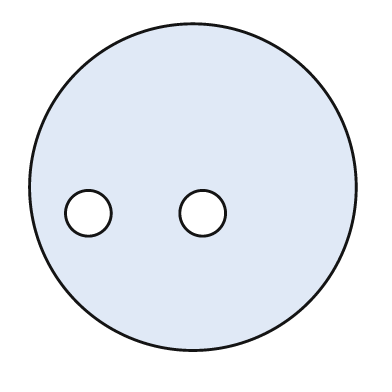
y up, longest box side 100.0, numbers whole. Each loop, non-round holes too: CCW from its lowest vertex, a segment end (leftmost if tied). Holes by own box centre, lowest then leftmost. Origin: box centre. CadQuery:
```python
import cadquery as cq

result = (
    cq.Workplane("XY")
    .moveTo(0.0, 0.0)
    .circle(50.0)
    .moveTo(-32.0, -8.0)
    .circle(7.0)
    .moveTo(3.0, -8.0)
    .circle(7.0)
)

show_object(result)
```